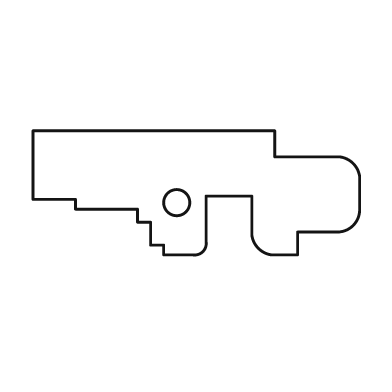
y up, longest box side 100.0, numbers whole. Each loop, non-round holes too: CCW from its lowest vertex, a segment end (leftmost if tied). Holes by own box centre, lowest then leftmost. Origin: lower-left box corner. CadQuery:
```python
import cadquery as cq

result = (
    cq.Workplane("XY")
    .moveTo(40.0, 0.0)
    .lineTo(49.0, 0.0)
    .threePointArc((52.0, 1.0), (53.0, 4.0))
    .lineTo(53.0, 18.0)
    .lineTo(67.0, 18.0)
    .lineTo(67.0, 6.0)
    .threePointArc((69.0, 2.0), (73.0, 0.0))
    .lineTo(81.0, 0.0)
    .lineTo(81.0, 7.0)
    .lineTo(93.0, 7.0)
    .threePointArc((98.0, 9.0), (100.0, 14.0))
    .lineTo(100.0, 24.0)
    .threePointArc((98.0, 28.0), (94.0, 30.0))
    .lineTo(74.0, 30.0)
    .lineTo(74.0, 38.0)
    .lineTo(0.0, 38.0)
    .lineTo(0.0, 17.0)
    .lineTo(13.0, 17.0)
    .lineTo(13.0, 14.0)
    .lineTo(32.0, 14.0)
    .lineTo(32.0, 10.0)
    .lineTo(36.0, 10.0)
    .lineTo(36.0, 3.0)
    .lineTo(40.0, 3.0)
    .close()
    .moveTo(44.0, 16.0)
    .circle(4.0)
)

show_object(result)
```